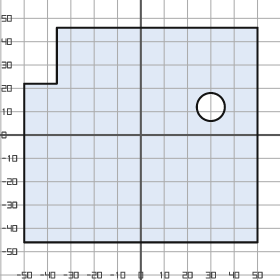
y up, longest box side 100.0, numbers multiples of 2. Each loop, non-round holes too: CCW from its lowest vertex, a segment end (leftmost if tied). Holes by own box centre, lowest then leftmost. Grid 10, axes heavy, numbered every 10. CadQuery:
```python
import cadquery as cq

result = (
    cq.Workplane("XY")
    .moveTo(-50.0, -46.0)
    .lineTo(50.0, -46.0)
    .lineTo(50.0, 46.0)
    .lineTo(-36.0, 46.0)
    .lineTo(-36.0, 22.0)
    .lineTo(-50.0, 22.0)
    .close()
    .moveTo(30.0, 12.0)
    .circle(6.0)
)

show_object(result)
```